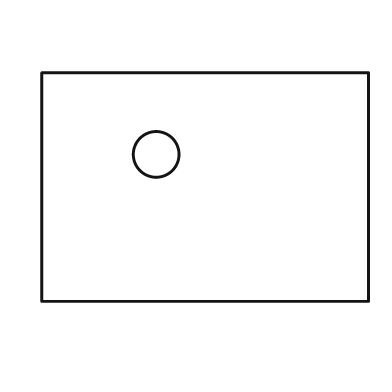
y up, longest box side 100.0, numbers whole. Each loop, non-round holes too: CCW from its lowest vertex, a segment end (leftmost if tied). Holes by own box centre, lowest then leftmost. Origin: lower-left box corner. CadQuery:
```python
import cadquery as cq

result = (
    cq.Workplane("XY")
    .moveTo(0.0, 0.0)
    .lineTo(100.0, 0.0)
    .lineTo(100.0, 70.0)
    .lineTo(0.0, 70.0)
    .close()
    .moveTo(35.0, 45.0)
    .circle(7.0)
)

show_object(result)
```